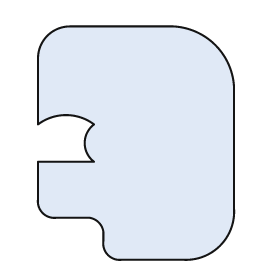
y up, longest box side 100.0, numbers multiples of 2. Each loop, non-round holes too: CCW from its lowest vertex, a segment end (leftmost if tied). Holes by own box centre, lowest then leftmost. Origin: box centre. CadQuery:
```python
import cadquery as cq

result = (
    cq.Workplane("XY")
    .moveTo(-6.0, -50.0)
    .lineTo(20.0, -50.0)
    .threePointArc((36.0, -44.0), (42.0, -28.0))
    .lineTo(42.0, 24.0)
    .threePointArc((34.0, 42.0), (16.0, 50.0))
    .lineTo(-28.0, 50.0)
    .threePointArc((-38.0, 46.0), (-42.0, 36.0))
    .lineTo(-42.0, 8.0)
    .threePointArc((-30.0, 12.0), (-18.0, 8.0))
    .threePointArc((-22.0, 0.0), (-18.0, -8.0))
    .lineTo(-42.0, -8.0)
    .lineTo(-42.0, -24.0)
    .threePointArc((-40.0, -30.0), (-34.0, -32.0))
    .lineTo(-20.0, -32.0)
    .threePointArc((-16.0, -34.0), (-14.0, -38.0))
    .lineTo(-14.0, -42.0)
    .threePointArc((-12.0, -48.0), (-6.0, -50.0))
    .close()
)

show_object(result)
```